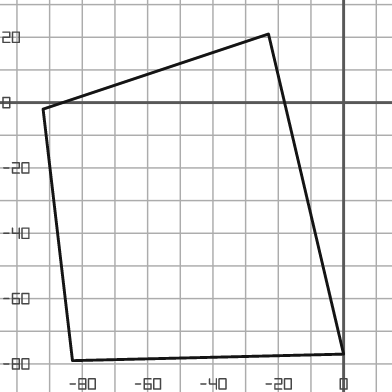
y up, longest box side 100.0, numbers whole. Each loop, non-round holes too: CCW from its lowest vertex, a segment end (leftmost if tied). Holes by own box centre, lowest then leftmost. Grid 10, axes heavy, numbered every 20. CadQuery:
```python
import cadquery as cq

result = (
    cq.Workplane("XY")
    .moveTo(-83.0, -79.0)
    .lineTo(0.0, -77.0)
    .lineTo(-23.0, 21.0)
    .lineTo(-92.0, -2.0)
    .close()
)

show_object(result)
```